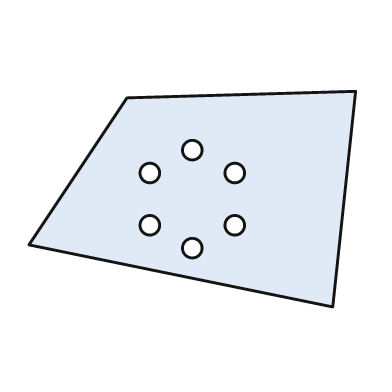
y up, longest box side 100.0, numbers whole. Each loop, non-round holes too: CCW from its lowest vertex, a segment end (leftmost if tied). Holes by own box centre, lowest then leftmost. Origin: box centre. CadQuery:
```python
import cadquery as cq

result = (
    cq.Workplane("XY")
    .moveTo(43.0, -33.0)
    .lineTo(50.0, 33.0)
    .lineTo(-20.0, 31.0)
    .lineTo(-50.0, -14.0)
    .close()
    .moveTo(0.0, -15.0)
    .circle(3.0)
    .moveTo(-13.0, -8.0)
    .circle(3.0)
    .moveTo(13.0, -8.0)
    .circle(3.0)
    .moveTo(-13.0, 8.0)
    .circle(3.0)
    .moveTo(13.0, 8.0)
    .circle(3.0)
    .moveTo(0.0, 15.0)
    .circle(3.0)
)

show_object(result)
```